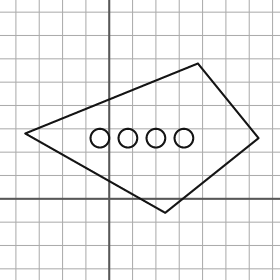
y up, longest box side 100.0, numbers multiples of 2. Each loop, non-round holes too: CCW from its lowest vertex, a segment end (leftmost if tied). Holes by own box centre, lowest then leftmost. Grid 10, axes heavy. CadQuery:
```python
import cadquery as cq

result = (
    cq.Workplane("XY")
    .moveTo(24.0, -6.0)
    .lineTo(64.0, 26.0)
    .lineTo(38.0, 58.0)
    .lineTo(-36.0, 28.0)
    .close()
    .moveTo(-4.0, 26.0)
    .circle(4.0)
    .moveTo(8.0, 26.0)
    .circle(4.0)
    .moveTo(20.0, 26.0)
    .circle(4.0)
    .moveTo(32.0, 26.0)
    .circle(4.0)
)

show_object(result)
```